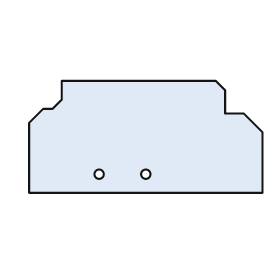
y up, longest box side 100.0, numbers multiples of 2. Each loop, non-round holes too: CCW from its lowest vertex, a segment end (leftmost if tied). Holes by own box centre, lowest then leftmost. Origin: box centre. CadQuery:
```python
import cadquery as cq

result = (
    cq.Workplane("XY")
    .moveTo(-50.0, -24.0)
    .lineTo(50.0, -24.0)
    .lineTo(50.0, 2.0)
    .lineTo(42.0, 10.0)
    .lineTo(34.0, 10.0)
    .lineTo(34.0, 20.0)
    .lineTo(30.0, 24.0)
    .lineTo(-36.0, 24.0)
    .lineTo(-36.0, 16.0)
    .lineTo(-40.0, 12.0)
    .lineTo(-44.0, 12.0)
    .lineTo(-50.0, 6.0)
    .close()
    .moveTo(-20.0, -16.0)
    .circle(2.0)
    .moveTo(0.0, -16.0)
    .circle(2.0)
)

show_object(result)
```